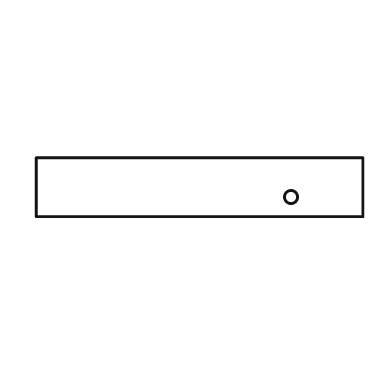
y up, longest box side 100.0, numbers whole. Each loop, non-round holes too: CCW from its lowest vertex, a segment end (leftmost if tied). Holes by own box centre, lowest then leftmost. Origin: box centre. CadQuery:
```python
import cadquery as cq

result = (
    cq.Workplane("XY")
    .moveTo(-50.0, -9.0)
    .lineTo(50.0, -9.0)
    .lineTo(50.0, 9.0)
    .lineTo(-50.0, 9.0)
    .close()
    .moveTo(28.0, -3.0)
    .circle(2.0)
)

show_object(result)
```